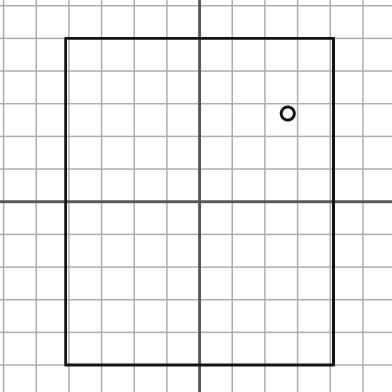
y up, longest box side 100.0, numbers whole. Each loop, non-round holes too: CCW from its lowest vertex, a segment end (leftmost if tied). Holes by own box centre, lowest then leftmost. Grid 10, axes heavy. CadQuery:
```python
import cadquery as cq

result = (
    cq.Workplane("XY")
    .moveTo(-41.0, -50.0)
    .lineTo(41.0, -50.0)
    .lineTo(41.0, 50.0)
    .lineTo(-41.0, 50.0)
    .close()
    .moveTo(27.0, 27.0)
    .circle(2.0)
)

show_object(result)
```